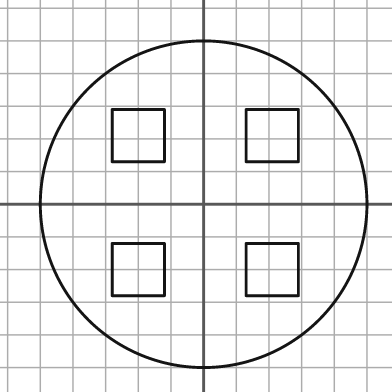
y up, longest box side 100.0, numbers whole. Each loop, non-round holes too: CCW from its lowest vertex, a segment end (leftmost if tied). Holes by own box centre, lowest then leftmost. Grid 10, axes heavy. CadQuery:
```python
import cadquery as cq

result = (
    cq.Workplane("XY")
    .moveTo(0.0, 0.0)
    .circle(50.0)
    .moveTo(-28.0, -28.0)
    .lineTo(-12.0, -28.0)
    .lineTo(-12.0, -12.0)
    .lineTo(-28.0, -12.0)
    .close()
    .moveTo(13.0, -28.0)
    .lineTo(29.0, -28.0)
    .lineTo(29.0, -12.0)
    .lineTo(13.0, -12.0)
    .close()
    .moveTo(-28.0, 13.0)
    .lineTo(-12.0, 13.0)
    .lineTo(-12.0, 29.0)
    .lineTo(-28.0, 29.0)
    .close()
    .moveTo(13.0, 13.0)
    .lineTo(29.0, 13.0)
    .lineTo(29.0, 29.0)
    .lineTo(13.0, 29.0)
    .close()
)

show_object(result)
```